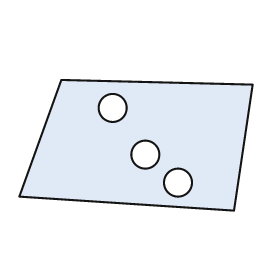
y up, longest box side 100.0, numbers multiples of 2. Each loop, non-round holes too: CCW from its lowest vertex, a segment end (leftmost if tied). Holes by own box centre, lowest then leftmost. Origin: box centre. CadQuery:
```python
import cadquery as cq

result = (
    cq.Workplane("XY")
    .moveTo(42.0, -28.0)
    .lineTo(50.0, 26.0)
    .lineTo(-32.0, 28.0)
    .lineTo(-50.0, -22.0)
    .close()
    .moveTo(18.0, -16.0)
    .circle(6.0)
    .moveTo(4.0, -4.0)
    .circle(6.0)
    .moveTo(-10.0, 16.0)
    .circle(6.0)
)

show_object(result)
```